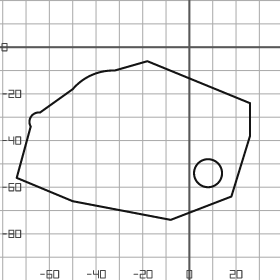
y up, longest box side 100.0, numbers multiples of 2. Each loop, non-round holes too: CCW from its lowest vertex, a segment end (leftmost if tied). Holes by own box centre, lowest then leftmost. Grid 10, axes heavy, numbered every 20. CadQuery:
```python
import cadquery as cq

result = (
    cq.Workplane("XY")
    .moveTo(-8.0, -74.0)
    .lineTo(18.0, -64.0)
    .lineTo(26.0, -38.0)
    .lineTo(26.0, -24.0)
    .lineTo(-18.0, -6.0)
    .lineTo(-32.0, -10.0)
    .threePointArc((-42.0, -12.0), (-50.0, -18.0))
    .lineTo(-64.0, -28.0)
    .threePointArc((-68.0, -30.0), (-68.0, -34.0))
    .lineTo(-74.0, -56.0)
    .lineTo(-50.0, -66.0)
    .close()
    .moveTo(8.0, -54.0)
    .circle(6.0)
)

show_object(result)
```